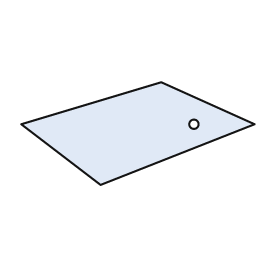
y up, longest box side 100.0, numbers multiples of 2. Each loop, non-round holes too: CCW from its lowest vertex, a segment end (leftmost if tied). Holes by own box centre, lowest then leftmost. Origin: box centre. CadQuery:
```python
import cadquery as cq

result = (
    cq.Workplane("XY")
    .moveTo(-16.0, -22.0)
    .lineTo(50.0, 4.0)
    .lineTo(10.0, 22.0)
    .lineTo(-50.0, 4.0)
    .close()
    .moveTo(24.0, 4.0)
    .circle(2.0)
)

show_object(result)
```